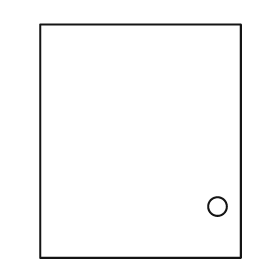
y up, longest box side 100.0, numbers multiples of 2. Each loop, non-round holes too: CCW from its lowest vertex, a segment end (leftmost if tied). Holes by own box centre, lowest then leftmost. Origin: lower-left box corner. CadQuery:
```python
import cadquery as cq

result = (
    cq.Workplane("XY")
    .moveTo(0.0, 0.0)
    .lineTo(86.0, 0.0)
    .lineTo(86.0, 100.0)
    .lineTo(0.0, 100.0)
    .close()
    .moveTo(76.0, 22.0)
    .circle(4.0)
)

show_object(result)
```